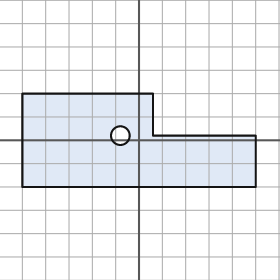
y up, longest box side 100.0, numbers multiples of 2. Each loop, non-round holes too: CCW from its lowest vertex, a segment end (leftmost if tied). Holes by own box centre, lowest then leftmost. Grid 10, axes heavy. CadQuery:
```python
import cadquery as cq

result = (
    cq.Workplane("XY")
    .moveTo(-50.0, -20.0)
    .lineTo(50.0, -20.0)
    .lineTo(50.0, 2.0)
    .lineTo(6.0, 2.0)
    .lineTo(6.0, 20.0)
    .lineTo(-50.0, 20.0)
    .close()
    .moveTo(-8.0, 2.0)
    .circle(4.0)
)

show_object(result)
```